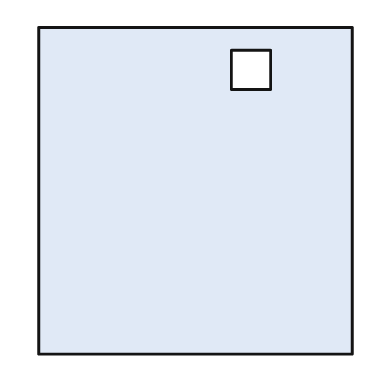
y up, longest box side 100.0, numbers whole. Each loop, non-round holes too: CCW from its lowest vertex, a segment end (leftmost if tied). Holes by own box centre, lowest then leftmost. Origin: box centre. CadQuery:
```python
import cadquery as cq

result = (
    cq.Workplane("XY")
    .moveTo(-48.0, -50.0)
    .lineTo(48.0, -50.0)
    .lineTo(48.0, 50.0)
    .lineTo(-48.0, 50.0)
    .close()
    .moveTo(11.0, 31.0)
    .lineTo(23.0, 31.0)
    .lineTo(23.0, 43.0)
    .lineTo(11.0, 43.0)
    .close()
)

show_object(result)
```